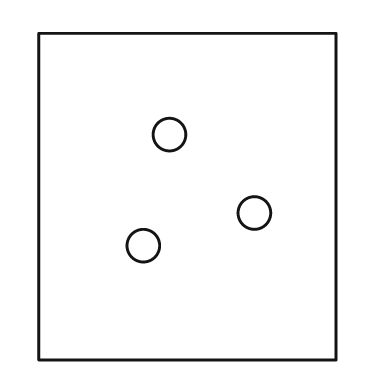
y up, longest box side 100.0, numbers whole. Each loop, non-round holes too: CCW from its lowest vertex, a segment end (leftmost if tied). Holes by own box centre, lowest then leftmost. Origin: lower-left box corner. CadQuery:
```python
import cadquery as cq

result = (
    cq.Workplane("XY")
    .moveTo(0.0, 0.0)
    .lineTo(91.0, 0.0)
    .lineTo(91.0, 100.0)
    .lineTo(0.0, 100.0)
    .close()
    .moveTo(32.0, 35.0)
    .circle(5.0)
    .moveTo(66.0, 45.0)
    .circle(5.0)
    .moveTo(40.0, 69.0)
    .circle(5.0)
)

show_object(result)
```